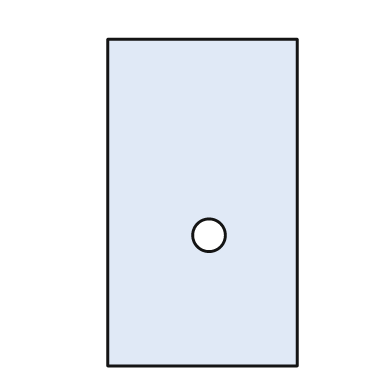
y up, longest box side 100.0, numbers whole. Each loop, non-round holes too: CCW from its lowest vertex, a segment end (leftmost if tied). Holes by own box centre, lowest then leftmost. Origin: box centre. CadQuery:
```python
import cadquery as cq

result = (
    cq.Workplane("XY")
    .moveTo(-29.0, -50.0)
    .lineTo(29.0, -50.0)
    .lineTo(29.0, 50.0)
    .lineTo(-29.0, 50.0)
    .close()
    .moveTo(2.0, -10.0)
    .circle(5.0)
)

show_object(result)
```